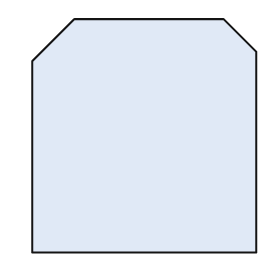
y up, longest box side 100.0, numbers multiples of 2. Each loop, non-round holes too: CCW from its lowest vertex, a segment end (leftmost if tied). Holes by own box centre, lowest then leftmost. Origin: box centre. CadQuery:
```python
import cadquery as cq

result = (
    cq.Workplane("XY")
    .moveTo(-48.0, -50.0)
    .lineTo(48.0, -50.0)
    .lineTo(48.0, 36.0)
    .lineTo(34.0, 50.0)
    .lineTo(-30.0, 50.0)
    .lineTo(-48.0, 32.0)
    .close()
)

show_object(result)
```